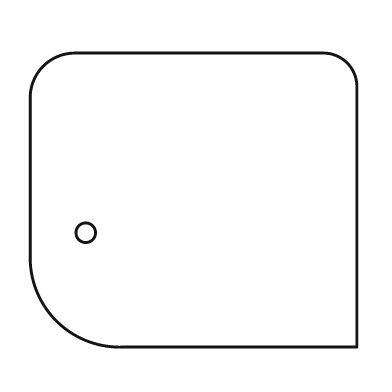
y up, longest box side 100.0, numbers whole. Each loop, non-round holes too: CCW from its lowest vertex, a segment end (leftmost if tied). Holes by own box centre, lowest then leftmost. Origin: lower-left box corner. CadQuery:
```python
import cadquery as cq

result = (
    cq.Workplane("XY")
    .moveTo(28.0, 0.0)
    .lineTo(100.0, 0.0)
    .lineTo(100.0, 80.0)
    .threePointArc((97.0, 87.0), (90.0, 90.0))
    .lineTo(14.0, 90.0)
    .threePointArc((4.0, 86.0), (0.0, 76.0))
    .lineTo(0.0, 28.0)
    .threePointArc((8.0, 8.0), (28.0, 0.0))
    .close()
    .moveTo(17.0, 35.0)
    .circle(3.0)
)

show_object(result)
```